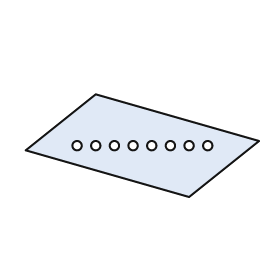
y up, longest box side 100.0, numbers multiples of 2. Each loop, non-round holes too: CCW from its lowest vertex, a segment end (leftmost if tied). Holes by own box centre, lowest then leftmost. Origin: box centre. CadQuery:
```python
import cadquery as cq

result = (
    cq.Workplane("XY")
    .moveTo(20.0, -22.0)
    .lineTo(50.0, 2.0)
    .lineTo(-20.0, 22.0)
    .lineTo(-50.0, -2.0)
    .close()
    .moveTo(-28.0, 0.0)
    .circle(2.0)
    .moveTo(-20.0, 0.0)
    .circle(2.0)
    .moveTo(-12.0, 0.0)
    .circle(2.0)
    .moveTo(-4.0, 0.0)
    .circle(2.0)
    .moveTo(4.0, 0.0)
    .circle(2.0)
    .moveTo(12.0, 0.0)
    .circle(2.0)
    .moveTo(20.0, 0.0)
    .circle(2.0)
    .moveTo(28.0, 0.0)
    .circle(2.0)
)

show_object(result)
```